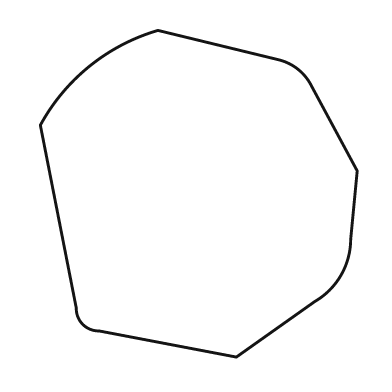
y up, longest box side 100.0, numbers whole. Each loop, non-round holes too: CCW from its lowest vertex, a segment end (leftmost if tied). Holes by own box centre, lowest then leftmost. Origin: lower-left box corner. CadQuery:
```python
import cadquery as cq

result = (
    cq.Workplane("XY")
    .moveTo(60.0, 0.0)
    .lineTo(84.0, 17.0)
    .threePointArc((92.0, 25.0), (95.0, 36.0))
    .lineTo(97.0, 57.0)
    .lineTo(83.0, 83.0)
    .threePointArc((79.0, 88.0), (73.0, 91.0))
    .lineTo(36.0, 100.0)
    .threePointArc((15.0, 89.0), (0.0, 71.0))
    .lineTo(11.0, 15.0)
    .threePointArc((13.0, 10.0), (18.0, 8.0))
    .close()
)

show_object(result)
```